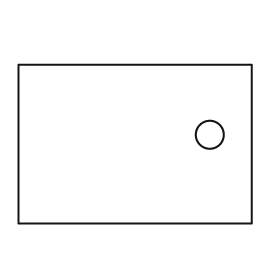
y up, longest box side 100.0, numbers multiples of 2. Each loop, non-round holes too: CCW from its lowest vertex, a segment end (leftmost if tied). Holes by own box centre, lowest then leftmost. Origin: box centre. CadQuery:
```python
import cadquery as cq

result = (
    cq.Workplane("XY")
    .moveTo(-50.0, -34.0)
    .lineTo(50.0, -34.0)
    .lineTo(50.0, 34.0)
    .lineTo(-50.0, 34.0)
    .close()
    .moveTo(32.0, 4.0)
    .circle(6.0)
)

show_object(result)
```